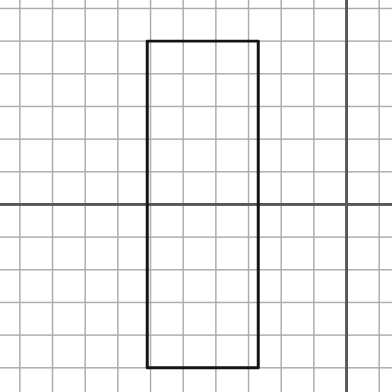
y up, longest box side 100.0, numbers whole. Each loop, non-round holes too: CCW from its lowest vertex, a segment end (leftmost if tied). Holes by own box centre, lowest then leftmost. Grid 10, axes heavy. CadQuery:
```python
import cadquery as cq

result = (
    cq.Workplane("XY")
    .moveTo(-61.0, -50.0)
    .lineTo(-27.0, -50.0)
    .lineTo(-27.0, 50.0)
    .lineTo(-61.0, 50.0)
    .close()
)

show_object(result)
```